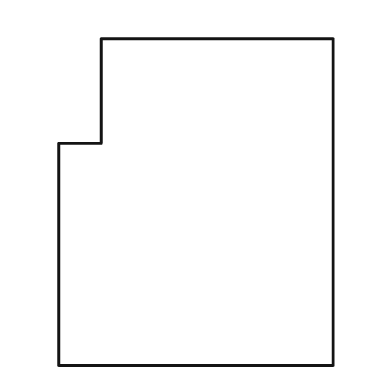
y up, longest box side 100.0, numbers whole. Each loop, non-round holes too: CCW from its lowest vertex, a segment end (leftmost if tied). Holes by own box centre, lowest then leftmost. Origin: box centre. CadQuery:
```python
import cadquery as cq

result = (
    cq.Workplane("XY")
    .moveTo(-42.0, -50.0)
    .lineTo(42.0, -50.0)
    .lineTo(42.0, 50.0)
    .lineTo(-29.0, 50.0)
    .lineTo(-29.0, 18.0)
    .lineTo(-42.0, 18.0)
    .close()
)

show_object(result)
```